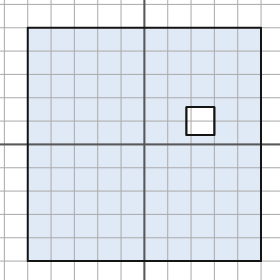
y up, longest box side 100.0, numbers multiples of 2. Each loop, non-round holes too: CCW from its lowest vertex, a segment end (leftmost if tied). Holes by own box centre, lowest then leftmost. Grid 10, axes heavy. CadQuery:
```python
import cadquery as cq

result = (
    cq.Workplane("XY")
    .moveTo(-50.0, -50.0)
    .lineTo(50.0, -50.0)
    .lineTo(50.0, 50.0)
    .lineTo(-50.0, 50.0)
    .close()
    .moveTo(18.0, 4.0)
    .lineTo(30.0, 4.0)
    .lineTo(30.0, 16.0)
    .lineTo(18.0, 16.0)
    .close()
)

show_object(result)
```